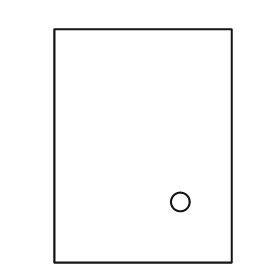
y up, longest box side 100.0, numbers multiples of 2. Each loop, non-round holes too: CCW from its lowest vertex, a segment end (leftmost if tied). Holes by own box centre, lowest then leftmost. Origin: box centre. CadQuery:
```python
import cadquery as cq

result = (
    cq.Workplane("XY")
    .moveTo(-38.0, -50.0)
    .lineTo(38.0, -50.0)
    .lineTo(38.0, 50.0)
    .lineTo(-38.0, 50.0)
    .close()
    .moveTo(16.0, -24.0)
    .circle(4.0)
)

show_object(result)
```